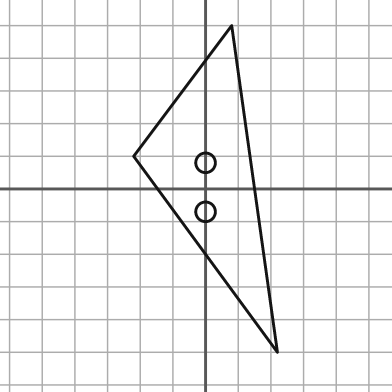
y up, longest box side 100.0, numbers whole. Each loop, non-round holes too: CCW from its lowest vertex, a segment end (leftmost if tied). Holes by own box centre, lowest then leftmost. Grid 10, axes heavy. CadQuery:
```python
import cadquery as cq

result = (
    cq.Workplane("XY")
    .moveTo(22.0, -50.0)
    .lineTo(8.0, 50.0)
    .lineTo(-22.0, 10.0)
    .close()
    .moveTo(0.0, -7.0)
    .circle(3.0)
    .moveTo(0.0, 8.0)
    .circle(3.0)
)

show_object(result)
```